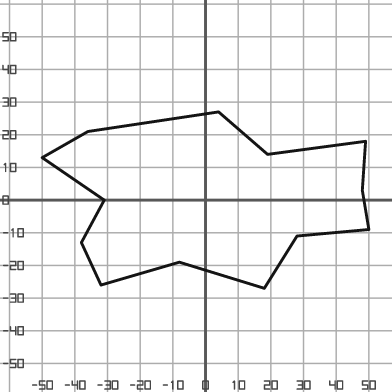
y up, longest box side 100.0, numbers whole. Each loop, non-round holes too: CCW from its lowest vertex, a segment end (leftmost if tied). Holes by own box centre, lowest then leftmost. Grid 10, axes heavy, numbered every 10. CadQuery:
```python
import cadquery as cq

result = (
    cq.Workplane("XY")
    .moveTo(18.0, -27.0)
    .lineTo(28.0, -11.0)
    .lineTo(50.0, -9.0)
    .lineTo(48.0, 3.0)
    .lineTo(49.0, 18.0)
    .lineTo(19.0, 14.0)
    .lineTo(4.0, 27.0)
    .lineTo(-36.0, 21.0)
    .lineTo(-50.0, 13.0)
    .lineTo(-31.0, 0.0)
    .lineTo(-38.0, -13.0)
    .lineTo(-32.0, -26.0)
    .lineTo(-8.0, -19.0)
    .close()
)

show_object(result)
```